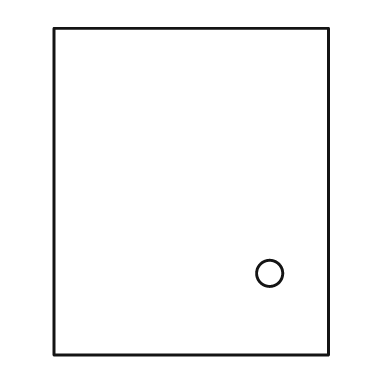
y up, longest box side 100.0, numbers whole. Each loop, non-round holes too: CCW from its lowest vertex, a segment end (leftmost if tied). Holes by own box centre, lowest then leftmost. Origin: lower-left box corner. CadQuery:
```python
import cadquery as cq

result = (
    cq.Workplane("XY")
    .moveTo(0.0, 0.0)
    .lineTo(84.0, 0.0)
    .lineTo(84.0, 100.0)
    .lineTo(0.0, 100.0)
    .close()
    .moveTo(66.0, 25.0)
    .circle(4.0)
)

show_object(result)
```